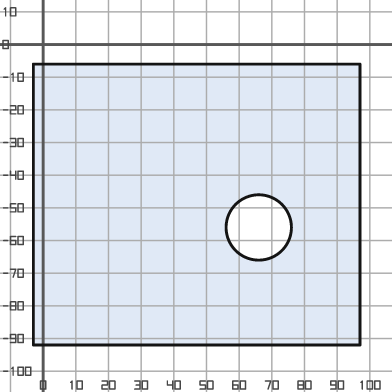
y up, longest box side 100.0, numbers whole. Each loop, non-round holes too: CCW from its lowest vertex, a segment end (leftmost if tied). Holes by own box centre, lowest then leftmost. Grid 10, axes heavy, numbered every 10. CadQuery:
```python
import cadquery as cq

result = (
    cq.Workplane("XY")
    .moveTo(-3.0, -92.0)
    .lineTo(97.0, -92.0)
    .lineTo(97.0, -6.0)
    .lineTo(-3.0, -6.0)
    .close()
    .moveTo(66.0, -56.0)
    .circle(10.0)
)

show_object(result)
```